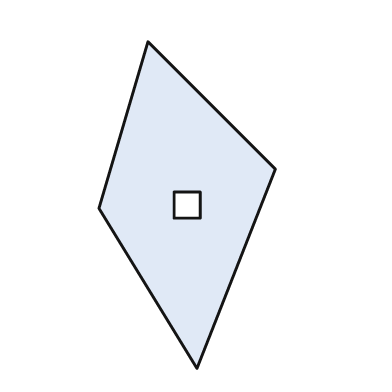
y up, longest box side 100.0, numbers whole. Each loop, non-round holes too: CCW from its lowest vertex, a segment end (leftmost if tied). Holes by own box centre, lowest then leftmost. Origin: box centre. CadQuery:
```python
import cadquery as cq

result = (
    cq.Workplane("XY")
    .moveTo(3.0, -50.0)
    .lineTo(27.0, 11.0)
    .lineTo(-12.0, 50.0)
    .lineTo(-27.0, -1.0)
    .close()
    .moveTo(-4.0, -4.0)
    .lineTo(4.0, -4.0)
    .lineTo(4.0, 4.0)
    .lineTo(-4.0, 4.0)
    .close()
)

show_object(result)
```